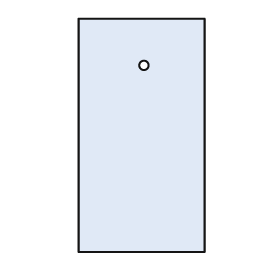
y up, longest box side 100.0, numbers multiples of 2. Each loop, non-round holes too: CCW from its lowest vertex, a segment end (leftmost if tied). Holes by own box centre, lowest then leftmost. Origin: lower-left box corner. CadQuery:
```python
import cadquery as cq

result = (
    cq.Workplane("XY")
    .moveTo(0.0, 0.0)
    .lineTo(54.0, 0.0)
    .lineTo(54.0, 100.0)
    .lineTo(0.0, 100.0)
    .close()
    .moveTo(28.0, 80.0)
    .circle(2.0)
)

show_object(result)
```